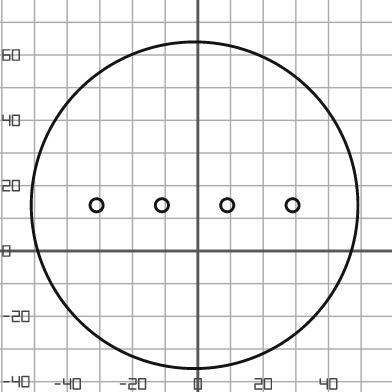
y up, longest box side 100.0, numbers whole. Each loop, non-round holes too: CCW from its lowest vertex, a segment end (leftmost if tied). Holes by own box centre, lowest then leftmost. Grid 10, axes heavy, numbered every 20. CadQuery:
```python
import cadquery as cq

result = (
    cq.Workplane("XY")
    .moveTo(-1.0, 14.0)
    .circle(50.0)
    .moveTo(-31.0, 14.0)
    .circle(2.0)
    .moveTo(-11.0, 14.0)
    .circle(2.0)
    .moveTo(9.0, 14.0)
    .circle(2.0)
    .moveTo(29.0, 14.0)
    .circle(2.0)
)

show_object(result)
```